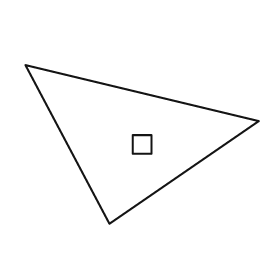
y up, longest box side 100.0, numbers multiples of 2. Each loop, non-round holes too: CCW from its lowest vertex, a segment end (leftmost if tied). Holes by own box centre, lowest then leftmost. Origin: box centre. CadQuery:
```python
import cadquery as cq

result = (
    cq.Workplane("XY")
    .moveTo(-14.0, -34.0)
    .lineTo(50.0, 10.0)
    .lineTo(-50.0, 34.0)
    .close()
    .moveTo(-4.0, -4.0)
    .lineTo(4.0, -4.0)
    .lineTo(4.0, 4.0)
    .lineTo(-4.0, 4.0)
    .close()
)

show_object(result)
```